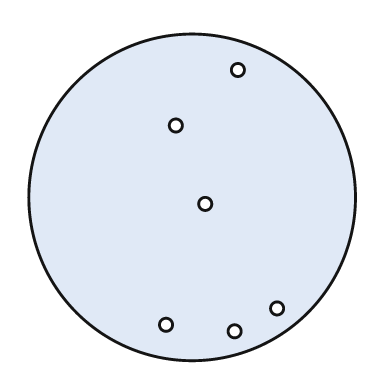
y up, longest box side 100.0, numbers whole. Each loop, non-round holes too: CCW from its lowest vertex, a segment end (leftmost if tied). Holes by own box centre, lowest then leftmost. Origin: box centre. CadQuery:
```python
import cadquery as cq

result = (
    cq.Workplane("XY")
    .moveTo(0.0, 0.0)
    .circle(50.0)
    .moveTo(13.0, -41.0)
    .circle(2.0)
    .moveTo(-8.0, -39.0)
    .circle(2.0)
    .moveTo(26.0, -34.0)
    .circle(2.0)
    .moveTo(4.0, -2.0)
    .circle(2.0)
    .moveTo(-5.0, 22.0)
    .circle(2.0)
    .moveTo(14.0, 39.0)
    .circle(2.0)
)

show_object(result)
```